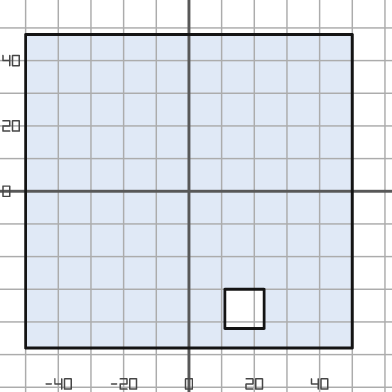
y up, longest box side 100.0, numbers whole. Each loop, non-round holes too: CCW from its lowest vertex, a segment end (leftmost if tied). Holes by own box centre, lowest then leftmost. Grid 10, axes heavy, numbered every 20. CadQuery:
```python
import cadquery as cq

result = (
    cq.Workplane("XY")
    .moveTo(-50.0, -48.0)
    .lineTo(50.0, -48.0)
    .lineTo(50.0, 48.0)
    .lineTo(-50.0, 48.0)
    .close()
    .moveTo(11.0, -42.0)
    .lineTo(23.0, -42.0)
    .lineTo(23.0, -30.0)
    .lineTo(11.0, -30.0)
    .close()
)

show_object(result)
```